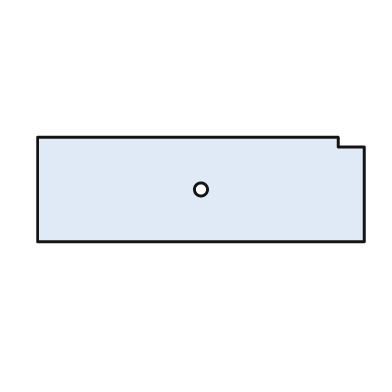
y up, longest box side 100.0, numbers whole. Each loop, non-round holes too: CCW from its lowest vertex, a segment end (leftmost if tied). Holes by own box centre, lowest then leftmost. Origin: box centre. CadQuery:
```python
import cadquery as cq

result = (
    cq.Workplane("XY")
    .moveTo(-50.0, -16.0)
    .lineTo(50.0, -16.0)
    .lineTo(50.0, 13.0)
    .lineTo(42.0, 13.0)
    .lineTo(42.0, 16.0)
    .lineTo(-50.0, 16.0)
    .close()
    .moveTo(0.0, 0.0)
    .circle(2.0)
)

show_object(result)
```